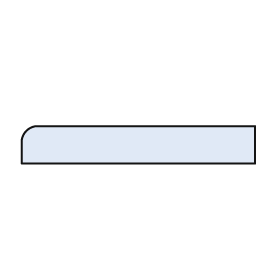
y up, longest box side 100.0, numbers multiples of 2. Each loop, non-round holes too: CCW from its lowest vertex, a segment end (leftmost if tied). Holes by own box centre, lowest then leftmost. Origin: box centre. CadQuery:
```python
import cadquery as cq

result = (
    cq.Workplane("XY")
    .moveTo(-50.0, -8.0)
    .lineTo(50.0, -8.0)
    .lineTo(50.0, 8.0)
    .lineTo(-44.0, 8.0)
    .threePointArc((-48.0, 6.0), (-50.0, 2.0))
    .close()
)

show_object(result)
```